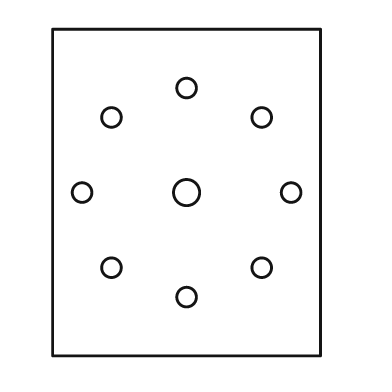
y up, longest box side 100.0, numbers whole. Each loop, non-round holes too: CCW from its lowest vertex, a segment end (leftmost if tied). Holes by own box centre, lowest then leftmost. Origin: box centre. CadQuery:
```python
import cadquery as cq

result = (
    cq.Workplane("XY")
    .moveTo(-41.0, -50.0)
    .lineTo(41.0, -50.0)
    .lineTo(41.0, 50.0)
    .lineTo(-41.0, 50.0)
    .close()
    .moveTo(0.0, -32.0)
    .circle(3.0)
    .moveTo(-23.0, -23.0)
    .circle(3.0)
    .moveTo(23.0, -23.0)
    .circle(3.0)
    .moveTo(-32.0, 0.0)
    .circle(3.0)
    .moveTo(0.0, 0.0)
    .circle(4.0)
    .moveTo(32.0, 0.0)
    .circle(3.0)
    .moveTo(-23.0, 23.0)
    .circle(3.0)
    .moveTo(23.0, 23.0)
    .circle(3.0)
    .moveTo(0.0, 32.0)
    .circle(3.0)
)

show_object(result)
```